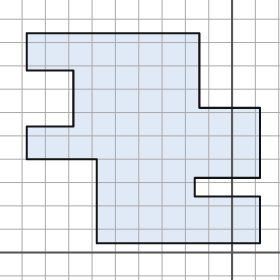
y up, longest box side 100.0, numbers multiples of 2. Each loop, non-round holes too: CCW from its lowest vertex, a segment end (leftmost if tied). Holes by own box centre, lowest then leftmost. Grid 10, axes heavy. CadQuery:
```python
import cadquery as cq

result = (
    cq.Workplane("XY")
    .moveTo(-58.0, 4.0)
    .lineTo(12.0, 4.0)
    .lineTo(12.0, 24.0)
    .lineTo(-16.0, 24.0)
    .lineTo(-16.0, 32.0)
    .lineTo(12.0, 32.0)
    .lineTo(12.0, 62.0)
    .lineTo(-14.0, 62.0)
    .lineTo(-14.0, 94.0)
    .lineTo(-88.0, 94.0)
    .lineTo(-88.0, 78.0)
    .lineTo(-68.0, 78.0)
    .lineTo(-68.0, 54.0)
    .lineTo(-88.0, 54.0)
    .lineTo(-88.0, 40.0)
    .lineTo(-58.0, 40.0)
    .close()
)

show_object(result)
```